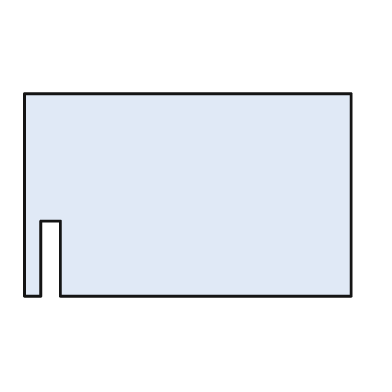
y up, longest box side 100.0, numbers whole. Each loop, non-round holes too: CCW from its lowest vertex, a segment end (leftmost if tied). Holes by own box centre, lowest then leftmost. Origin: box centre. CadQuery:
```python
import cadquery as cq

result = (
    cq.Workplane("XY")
    .moveTo(-50.0, -31.0)
    .lineTo(-45.0, -31.0)
    .lineTo(-45.0, -8.0)
    .lineTo(-39.0, -8.0)
    .lineTo(-39.0, -31.0)
    .lineTo(50.0, -31.0)
    .lineTo(50.0, 31.0)
    .lineTo(-50.0, 31.0)
    .close()
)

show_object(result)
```